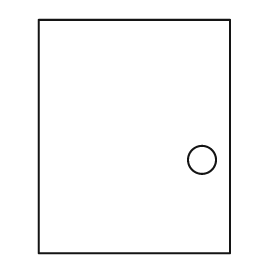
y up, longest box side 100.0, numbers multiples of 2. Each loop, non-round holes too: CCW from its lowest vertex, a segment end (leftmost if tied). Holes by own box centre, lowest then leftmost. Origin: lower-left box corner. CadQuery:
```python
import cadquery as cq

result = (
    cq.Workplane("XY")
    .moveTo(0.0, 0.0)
    .lineTo(82.0, 0.0)
    .lineTo(82.0, 100.0)
    .lineTo(0.0, 100.0)
    .close()
    .moveTo(70.0, 40.0)
    .circle(6.0)
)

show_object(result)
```